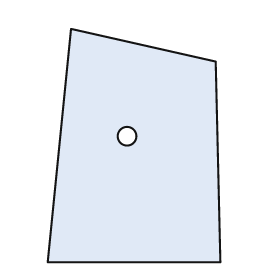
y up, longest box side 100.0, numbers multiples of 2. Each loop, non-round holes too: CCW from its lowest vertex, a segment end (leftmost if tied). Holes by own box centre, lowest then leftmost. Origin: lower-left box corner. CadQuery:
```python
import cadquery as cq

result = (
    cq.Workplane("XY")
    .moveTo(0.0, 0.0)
    .lineTo(74.0, 0.0)
    .lineTo(72.0, 86.0)
    .lineTo(10.0, 100.0)
    .close()
    .moveTo(34.0, 54.0)
    .circle(4.0)
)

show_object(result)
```